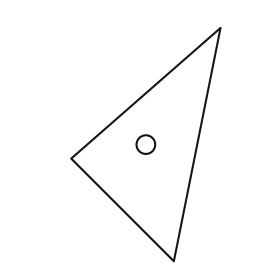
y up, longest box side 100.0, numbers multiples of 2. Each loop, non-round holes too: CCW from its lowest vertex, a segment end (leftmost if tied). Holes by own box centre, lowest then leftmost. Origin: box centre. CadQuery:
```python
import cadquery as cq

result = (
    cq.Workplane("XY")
    .moveTo(12.0, -50.0)
    .lineTo(32.0, 50.0)
    .lineTo(-32.0, -6.0)
    .close()
    .moveTo(0.0, 0.0)
    .circle(4.0)
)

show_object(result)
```